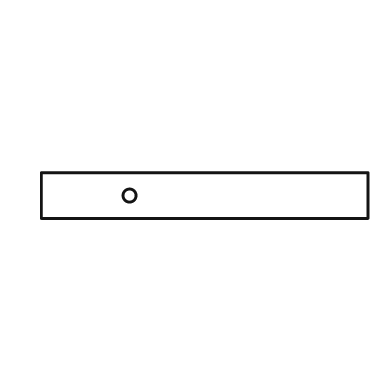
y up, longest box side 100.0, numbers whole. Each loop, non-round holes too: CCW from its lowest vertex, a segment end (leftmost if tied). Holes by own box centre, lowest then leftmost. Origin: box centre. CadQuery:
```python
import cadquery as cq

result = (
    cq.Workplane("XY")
    .moveTo(-50.0, -7.0)
    .lineTo(50.0, -7.0)
    .lineTo(50.0, 7.0)
    .lineTo(-50.0, 7.0)
    .close()
    .moveTo(-23.0, 0.0)
    .circle(2.0)
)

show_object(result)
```